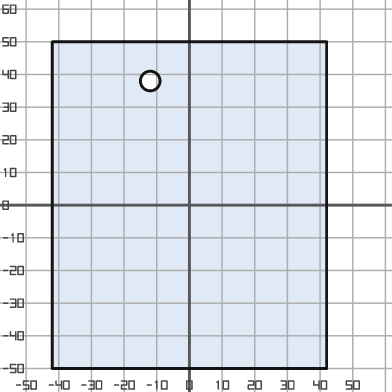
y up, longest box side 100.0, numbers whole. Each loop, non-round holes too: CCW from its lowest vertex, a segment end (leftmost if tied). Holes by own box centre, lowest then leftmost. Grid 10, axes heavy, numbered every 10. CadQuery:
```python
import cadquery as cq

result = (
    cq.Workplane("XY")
    .moveTo(-42.0, -50.0)
    .lineTo(42.0, -50.0)
    .lineTo(42.0, 50.0)
    .lineTo(-42.0, 50.0)
    .close()
    .moveTo(-12.0, 38.0)
    .circle(3.0)
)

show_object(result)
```